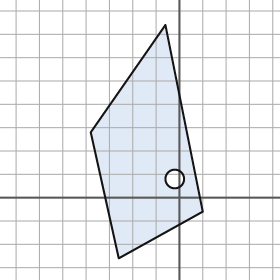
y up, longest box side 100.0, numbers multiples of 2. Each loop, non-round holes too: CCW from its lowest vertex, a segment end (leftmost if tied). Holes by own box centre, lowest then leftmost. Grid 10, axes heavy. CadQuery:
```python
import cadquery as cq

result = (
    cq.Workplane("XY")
    .moveTo(-26.0, -26.0)
    .lineTo(10.0, -6.0)
    .lineTo(-6.0, 74.0)
    .lineTo(-38.0, 28.0)
    .close()
    .moveTo(-2.0, 8.0)
    .circle(4.0)
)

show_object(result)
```